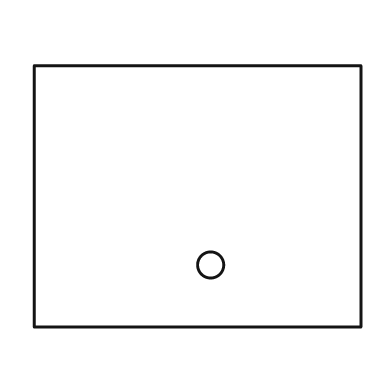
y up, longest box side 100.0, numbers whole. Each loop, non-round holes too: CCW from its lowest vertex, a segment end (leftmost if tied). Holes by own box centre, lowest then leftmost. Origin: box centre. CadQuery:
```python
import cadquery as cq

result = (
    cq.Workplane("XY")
    .moveTo(-50.0, -40.0)
    .lineTo(50.0, -40.0)
    .lineTo(50.0, 40.0)
    .lineTo(-50.0, 40.0)
    .close()
    .moveTo(4.0, -21.0)
    .circle(4.0)
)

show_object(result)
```